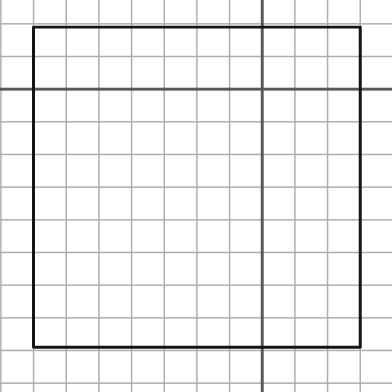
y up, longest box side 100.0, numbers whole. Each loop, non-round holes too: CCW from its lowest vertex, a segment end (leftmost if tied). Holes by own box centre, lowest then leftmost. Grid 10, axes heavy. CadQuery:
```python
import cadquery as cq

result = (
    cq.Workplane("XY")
    .moveTo(-70.0, -79.0)
    .lineTo(30.0, -79.0)
    .lineTo(30.0, 19.0)
    .lineTo(-70.0, 19.0)
    .close()
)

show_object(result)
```